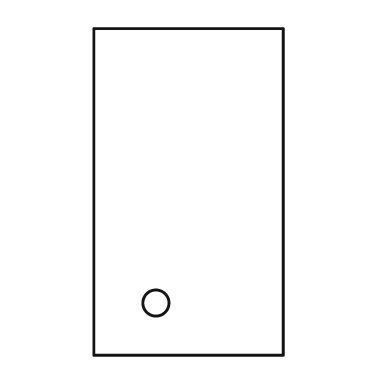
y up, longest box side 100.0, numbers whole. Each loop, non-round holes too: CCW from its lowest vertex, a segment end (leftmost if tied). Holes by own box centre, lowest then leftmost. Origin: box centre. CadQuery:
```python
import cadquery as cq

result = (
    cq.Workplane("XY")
    .moveTo(-29.0, -50.0)
    .lineTo(29.0, -50.0)
    .lineTo(29.0, 50.0)
    .lineTo(-29.0, 50.0)
    .close()
    .moveTo(-10.0, -34.0)
    .circle(4.0)
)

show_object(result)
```